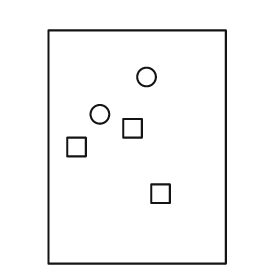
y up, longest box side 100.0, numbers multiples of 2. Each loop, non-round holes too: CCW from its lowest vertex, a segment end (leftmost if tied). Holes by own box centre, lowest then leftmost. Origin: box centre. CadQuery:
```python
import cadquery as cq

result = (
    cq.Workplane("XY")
    .moveTo(-38.0, -50.0)
    .lineTo(38.0, -50.0)
    .lineTo(38.0, 50.0)
    .lineTo(-38.0, 50.0)
    .close()
    .moveTo(6.0, -24.0)
    .lineTo(14.0, -24.0)
    .lineTo(14.0, -16.0)
    .lineTo(6.0, -16.0)
    .close()
    .moveTo(-30.0, -4.0)
    .lineTo(-22.0, -4.0)
    .lineTo(-22.0, 4.0)
    .lineTo(-30.0, 4.0)
    .close()
    .moveTo(-6.0, 4.0)
    .lineTo(2.0, 4.0)
    .lineTo(2.0, 12.0)
    .lineTo(-6.0, 12.0)
    .close()
    .moveTo(-16.0, 14.0)
    .circle(4.0)
    .moveTo(4.0, 30.0)
    .circle(4.0)
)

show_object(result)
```